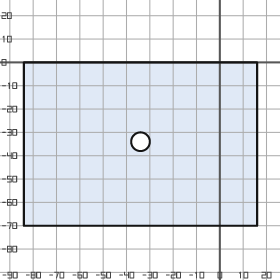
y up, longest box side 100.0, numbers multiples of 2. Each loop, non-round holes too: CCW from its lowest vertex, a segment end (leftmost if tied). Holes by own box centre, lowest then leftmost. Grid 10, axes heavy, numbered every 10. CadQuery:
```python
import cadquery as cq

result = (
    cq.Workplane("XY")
    .moveTo(-84.0, -70.0)
    .lineTo(16.0, -70.0)
    .lineTo(16.0, 0.0)
    .lineTo(-84.0, 0.0)
    .close()
    .moveTo(-34.0, -34.0)
    .circle(4.0)
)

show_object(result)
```